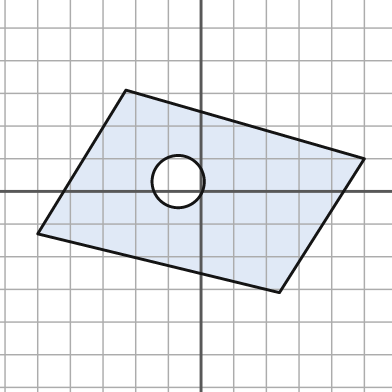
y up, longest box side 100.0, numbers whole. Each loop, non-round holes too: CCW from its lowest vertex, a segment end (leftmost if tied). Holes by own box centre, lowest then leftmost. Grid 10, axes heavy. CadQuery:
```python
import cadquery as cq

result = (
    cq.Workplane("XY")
    .moveTo(24.0, -31.0)
    .lineTo(50.0, 10.0)
    .lineTo(-23.0, 31.0)
    .lineTo(-50.0, -13.0)
    .close()
    .moveTo(-7.0, 3.0)
    .circle(8.0)
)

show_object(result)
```